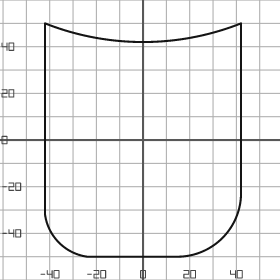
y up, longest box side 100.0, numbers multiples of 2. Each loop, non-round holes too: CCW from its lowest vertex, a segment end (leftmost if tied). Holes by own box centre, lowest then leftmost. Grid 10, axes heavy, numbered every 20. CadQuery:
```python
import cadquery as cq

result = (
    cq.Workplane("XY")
    .moveTo(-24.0, -50.0)
    .lineTo(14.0, -50.0)
    .threePointArc((34.0, -42.0), (42.0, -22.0))
    .lineTo(42.0, 50.0)
    .threePointArc((0.0, 42.0), (-42.0, 50.0))
    .lineTo(-42.0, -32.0)
    .threePointArc((-36.0, -44.0), (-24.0, -50.0))
    .close()
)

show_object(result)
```